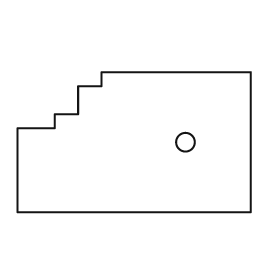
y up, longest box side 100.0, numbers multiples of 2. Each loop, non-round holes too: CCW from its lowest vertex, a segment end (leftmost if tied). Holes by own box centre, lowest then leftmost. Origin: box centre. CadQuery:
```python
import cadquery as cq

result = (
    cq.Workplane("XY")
    .moveTo(-50.0, -30.0)
    .lineTo(50.0, -30.0)
    .lineTo(50.0, 30.0)
    .lineTo(-14.0, 30.0)
    .lineTo(-14.0, 24.0)
    .lineTo(-24.0, 24.0)
    .lineTo(-24.0, 12.0)
    .lineTo(-34.0, 12.0)
    .lineTo(-34.0, 6.0)
    .lineTo(-50.0, 6.0)
    .close()
    .moveTo(22.0, 0.0)
    .circle(4.0)
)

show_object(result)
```